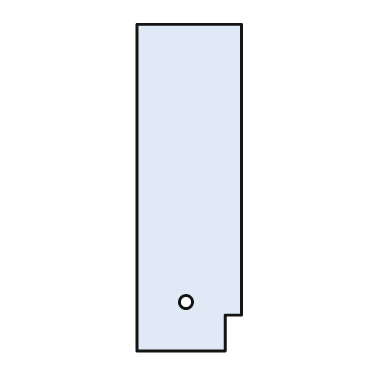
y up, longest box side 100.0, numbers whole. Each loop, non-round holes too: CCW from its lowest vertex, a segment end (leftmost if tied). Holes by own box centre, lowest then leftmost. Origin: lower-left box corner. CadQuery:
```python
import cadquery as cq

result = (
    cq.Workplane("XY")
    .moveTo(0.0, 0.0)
    .lineTo(27.0, 0.0)
    .lineTo(27.0, 11.0)
    .lineTo(32.0, 11.0)
    .lineTo(32.0, 100.0)
    .lineTo(0.0, 100.0)
    .close()
    .moveTo(15.0, 15.0)
    .circle(2.0)
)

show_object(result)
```